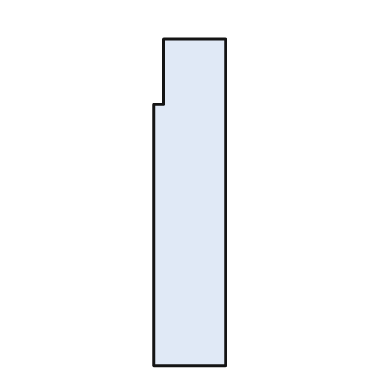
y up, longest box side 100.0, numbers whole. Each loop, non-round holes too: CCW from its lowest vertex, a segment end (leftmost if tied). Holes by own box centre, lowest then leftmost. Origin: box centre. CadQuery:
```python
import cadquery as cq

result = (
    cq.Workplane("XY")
    .moveTo(-11.0, -50.0)
    .lineTo(11.0, -50.0)
    .lineTo(11.0, 50.0)
    .lineTo(-8.0, 50.0)
    .lineTo(-8.0, 30.0)
    .lineTo(-11.0, 30.0)
    .close()
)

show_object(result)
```